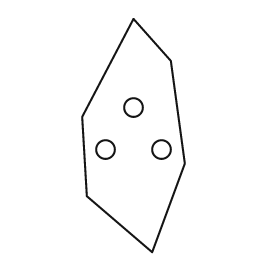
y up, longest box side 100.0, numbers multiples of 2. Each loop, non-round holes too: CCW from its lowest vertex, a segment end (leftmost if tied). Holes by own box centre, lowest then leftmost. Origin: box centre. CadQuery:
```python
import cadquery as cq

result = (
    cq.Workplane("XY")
    .moveTo(8.0, -50.0)
    .lineTo(22.0, -12.0)
    .lineTo(16.0, 32.0)
    .lineTo(0.0, 50.0)
    .lineTo(-22.0, 8.0)
    .lineTo(-20.0, -26.0)
    .close()
    .moveTo(-12.0, -6.0)
    .circle(4.0)
    .moveTo(12.0, -6.0)
    .circle(4.0)
    .moveTo(0.0, 12.0)
    .circle(4.0)
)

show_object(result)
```